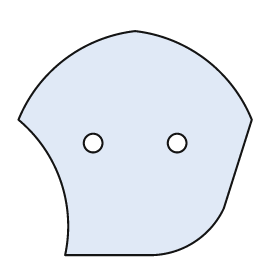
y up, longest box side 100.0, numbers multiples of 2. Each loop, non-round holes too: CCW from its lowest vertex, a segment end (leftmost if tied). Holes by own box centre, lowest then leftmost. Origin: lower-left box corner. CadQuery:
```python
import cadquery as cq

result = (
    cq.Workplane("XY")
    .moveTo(20.0, 0.0)
    .lineTo(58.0, 0.0)
    .threePointArc((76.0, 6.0), (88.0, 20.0))
    .lineTo(100.0, 58.0)
    .threePointArc((80.0, 84.0), (50.0, 96.0))
    .threePointArc((20.0, 84.0), (0.0, 58.0))
    .threePointArc((18.0, 32.0), (20.0, 0.0))
    .close()
    .moveTo(32.0, 48.0)
    .circle(4.0)
    .moveTo(68.0, 48.0)
    .circle(4.0)
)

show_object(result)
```